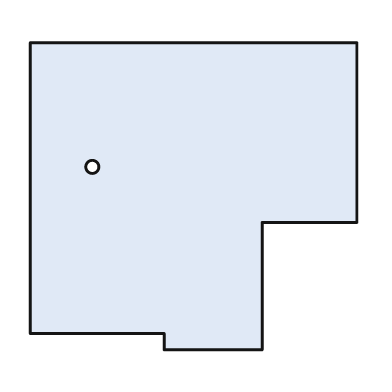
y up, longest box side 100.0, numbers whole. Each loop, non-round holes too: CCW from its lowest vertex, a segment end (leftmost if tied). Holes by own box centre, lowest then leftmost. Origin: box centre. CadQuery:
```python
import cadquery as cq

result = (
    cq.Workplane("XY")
    .moveTo(-9.0, -47.0)
    .lineTo(21.0, -47.0)
    .lineTo(21.0, -8.0)
    .lineTo(50.0, -8.0)
    .lineTo(50.0, 47.0)
    .lineTo(-50.0, 47.0)
    .lineTo(-50.0, -42.0)
    .lineTo(-9.0, -42.0)
    .close()
    .moveTo(-31.0, 9.0)
    .circle(2.0)
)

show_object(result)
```